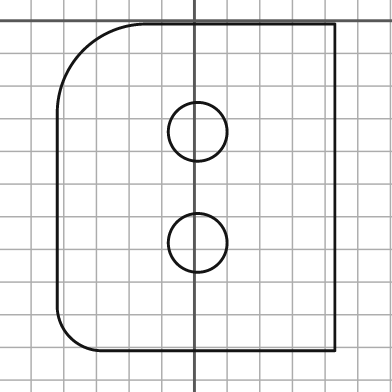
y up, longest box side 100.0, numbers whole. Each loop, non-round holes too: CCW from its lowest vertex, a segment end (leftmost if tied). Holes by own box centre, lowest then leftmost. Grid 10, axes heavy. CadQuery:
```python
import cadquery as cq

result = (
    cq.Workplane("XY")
    .moveTo(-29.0, -101.0)
    .lineTo(43.0, -101.0)
    .lineTo(43.0, -1.0)
    .lineTo(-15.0, -1.0)
    .threePointArc((-34.0, -9.0), (-42.0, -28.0))
    .lineTo(-42.0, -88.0)
    .threePointArc((-38.0, -97.0), (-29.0, -101.0))
    .close()
    .moveTo(1.0, -68.0)
    .circle(9.0)
    .moveTo(1.0, -34.0)
    .circle(9.0)
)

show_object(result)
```